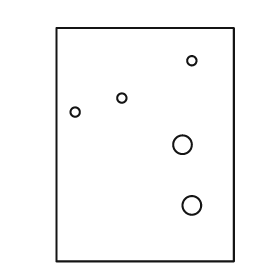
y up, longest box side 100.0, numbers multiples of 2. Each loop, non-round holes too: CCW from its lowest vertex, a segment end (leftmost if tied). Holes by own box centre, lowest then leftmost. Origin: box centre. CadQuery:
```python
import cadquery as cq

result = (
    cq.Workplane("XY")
    .moveTo(-38.0, -50.0)
    .lineTo(38.0, -50.0)
    .lineTo(38.0, 50.0)
    .lineTo(-38.0, 50.0)
    .close()
    .moveTo(20.0, -26.0)
    .circle(4.0)
    .moveTo(16.0, 0.0)
    .circle(4.0)
    .moveTo(-30.0, 14.0)
    .circle(2.0)
    .moveTo(-10.0, 20.0)
    .circle(2.0)
    .moveTo(20.0, 36.0)
    .circle(2.0)
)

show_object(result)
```